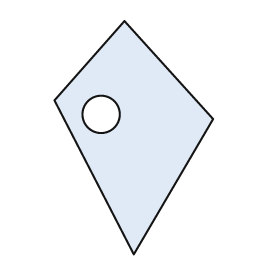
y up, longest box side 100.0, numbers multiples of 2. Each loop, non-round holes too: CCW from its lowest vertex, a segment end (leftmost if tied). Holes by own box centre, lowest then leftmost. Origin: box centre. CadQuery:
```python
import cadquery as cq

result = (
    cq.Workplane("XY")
    .moveTo(0.0, -50.0)
    .lineTo(34.0, 8.0)
    .lineTo(-4.0, 50.0)
    .lineTo(-34.0, 16.0)
    .close()
    .moveTo(-14.0, 10.0)
    .circle(8.0)
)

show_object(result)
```